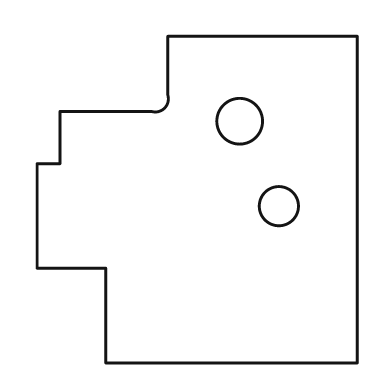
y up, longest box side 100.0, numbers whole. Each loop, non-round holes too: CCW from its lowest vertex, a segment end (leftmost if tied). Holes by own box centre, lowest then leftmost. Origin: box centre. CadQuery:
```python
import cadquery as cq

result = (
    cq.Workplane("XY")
    .moveTo(-28.0, -50.0)
    .lineTo(49.0, -50.0)
    .lineTo(49.0, 50.0)
    .lineTo(-9.0, 50.0)
    .lineTo(-9.0, 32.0)
    .threePointArc((-10.0, 28.0), (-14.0, 27.0))
    .lineTo(-42.0, 27.0)
    .lineTo(-42.0, 11.0)
    .lineTo(-49.0, 11.0)
    .lineTo(-49.0, -21.0)
    .lineTo(-28.0, -21.0)
    .close()
    .moveTo(25.0, -2.0)
    .circle(6.0)
    .moveTo(13.0, 24.0)
    .circle(7.0)
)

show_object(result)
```